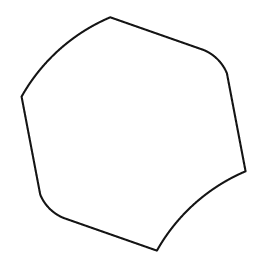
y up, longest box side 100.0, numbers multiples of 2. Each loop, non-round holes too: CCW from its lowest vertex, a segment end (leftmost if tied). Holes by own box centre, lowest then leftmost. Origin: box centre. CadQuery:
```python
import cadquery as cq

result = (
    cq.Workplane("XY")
    .moveTo(10.0, -50.0)
    .threePointArc((26.0, -30.0), (48.0, -16.0))
    .lineTo(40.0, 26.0)
    .threePointArc((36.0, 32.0), (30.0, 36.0))
    .lineTo(-10.0, 50.0)
    .threePointArc((-32.0, 36.0), (-48.0, 16.0))
    .lineTo(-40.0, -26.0)
    .threePointArc((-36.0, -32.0), (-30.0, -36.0))
    .close()
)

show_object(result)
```